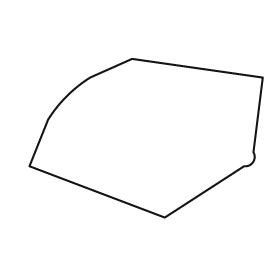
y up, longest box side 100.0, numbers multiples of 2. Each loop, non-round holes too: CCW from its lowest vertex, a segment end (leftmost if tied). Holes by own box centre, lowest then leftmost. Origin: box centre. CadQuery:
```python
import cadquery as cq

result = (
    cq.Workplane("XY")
    .moveTo(8.0, -34.0)
    .lineTo(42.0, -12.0)
    .threePointArc((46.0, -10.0), (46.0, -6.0))
    .lineTo(50.0, 26.0)
    .lineTo(-6.0, 34.0)
    .lineTo(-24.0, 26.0)
    .threePointArc((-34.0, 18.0), (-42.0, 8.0))
    .lineTo(-50.0, -12.0)
    .close()
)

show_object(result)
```